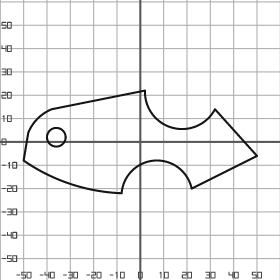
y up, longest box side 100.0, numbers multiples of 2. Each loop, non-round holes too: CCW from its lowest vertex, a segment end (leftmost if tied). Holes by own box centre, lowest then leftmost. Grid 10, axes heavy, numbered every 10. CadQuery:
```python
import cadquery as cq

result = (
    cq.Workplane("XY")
    .moveTo(-8.0, -22.0)
    .threePointArc((6.0, -8.0), (22.0, -20.0))
    .lineTo(50.0, -6.0)
    .lineTo(32.0, 14.0)
    .threePointArc((14.0, 6.0), (2.0, 22.0))
    .lineTo(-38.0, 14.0)
    .threePointArc((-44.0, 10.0), (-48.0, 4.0))
    .lineTo(-50.0, -8.0)
    .threePointArc((-30.0, -18.0), (-8.0, -22.0))
    .close()
    .moveTo(-36.0, 2.0)
    .circle(4.0)
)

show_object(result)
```